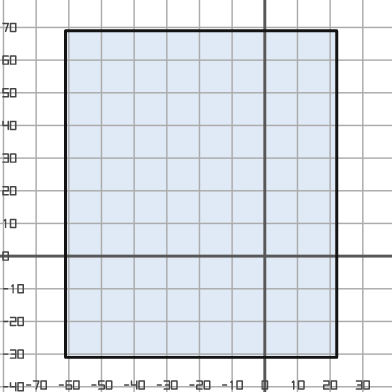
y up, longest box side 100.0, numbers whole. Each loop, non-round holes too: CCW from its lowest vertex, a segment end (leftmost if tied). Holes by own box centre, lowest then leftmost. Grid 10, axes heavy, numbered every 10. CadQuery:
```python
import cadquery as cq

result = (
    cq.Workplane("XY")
    .moveTo(-61.0, -31.0)
    .lineTo(22.0, -31.0)
    .lineTo(22.0, 69.0)
    .lineTo(-61.0, 69.0)
    .close()
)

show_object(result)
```